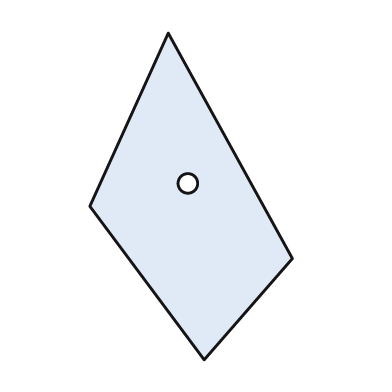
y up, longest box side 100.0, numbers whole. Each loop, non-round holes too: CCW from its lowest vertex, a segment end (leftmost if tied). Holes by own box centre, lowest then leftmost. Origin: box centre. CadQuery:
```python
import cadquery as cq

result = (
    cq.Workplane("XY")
    .moveTo(4.0, -50.0)
    .lineTo(31.0, -19.0)
    .lineTo(-7.0, 50.0)
    .lineTo(-31.0, -3.0)
    .close()
    .moveTo(-1.0, 4.0)
    .circle(3.0)
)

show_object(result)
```